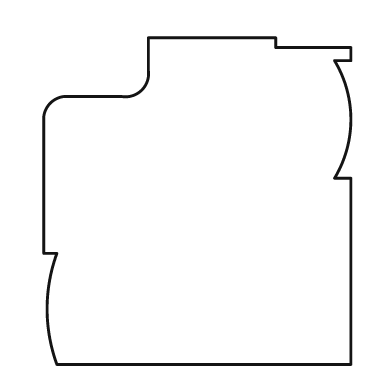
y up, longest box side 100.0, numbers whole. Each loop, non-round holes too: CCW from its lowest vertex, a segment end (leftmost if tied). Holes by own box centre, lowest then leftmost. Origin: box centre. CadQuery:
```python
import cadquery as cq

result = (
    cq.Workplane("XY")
    .moveTo(-43.0, -50.0)
    .lineTo(47.0, -50.0)
    .lineTo(47.0, 7.0)
    .lineTo(42.0, 7.0)
    .threePointArc((47.0, 25.0), (42.0, 43.0))
    .lineTo(47.0, 43.0)
    .lineTo(47.0, 47.0)
    .lineTo(24.0, 47.0)
    .lineTo(24.0, 50.0)
    .lineTo(-15.0, 50.0)
    .lineTo(-15.0, 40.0)
    .threePointArc((-17.0, 34.0), (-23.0, 32.0))
    .lineTo(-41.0, 32.0)
    .threePointArc((-45.0, 30.0), (-47.0, 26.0))
    .lineTo(-47.0, -16.0)
    .lineTo(-43.0, -16.0)
    .threePointArc((-46.0, -33.0), (-43.0, -50.0))
    .close()
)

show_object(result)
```